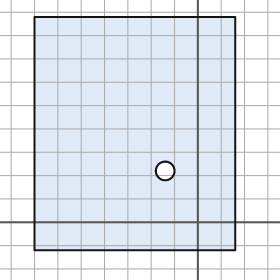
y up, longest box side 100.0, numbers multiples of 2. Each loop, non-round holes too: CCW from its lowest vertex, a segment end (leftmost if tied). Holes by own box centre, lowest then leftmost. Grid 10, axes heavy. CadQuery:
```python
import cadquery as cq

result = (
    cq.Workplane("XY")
    .moveTo(-70.0, -12.0)
    .lineTo(16.0, -12.0)
    .lineTo(16.0, 88.0)
    .lineTo(-70.0, 88.0)
    .close()
    .moveTo(-14.0, 22.0)
    .circle(4.0)
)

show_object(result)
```